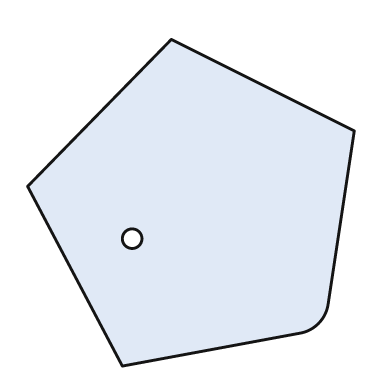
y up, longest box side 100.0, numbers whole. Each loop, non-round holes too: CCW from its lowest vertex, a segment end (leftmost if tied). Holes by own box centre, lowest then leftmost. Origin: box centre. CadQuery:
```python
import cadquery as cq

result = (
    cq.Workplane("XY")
    .moveTo(-21.0, -50.0)
    .lineTo(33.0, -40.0)
    .threePointArc((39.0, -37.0), (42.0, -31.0))
    .lineTo(50.0, 22.0)
    .lineTo(-6.0, 50.0)
    .lineTo(-50.0, 5.0)
    .close()
    .moveTo(-18.0, -11.0)
    .circle(3.0)
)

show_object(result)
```